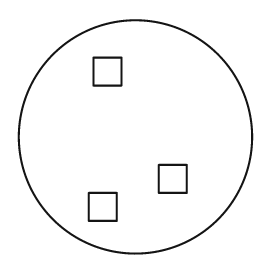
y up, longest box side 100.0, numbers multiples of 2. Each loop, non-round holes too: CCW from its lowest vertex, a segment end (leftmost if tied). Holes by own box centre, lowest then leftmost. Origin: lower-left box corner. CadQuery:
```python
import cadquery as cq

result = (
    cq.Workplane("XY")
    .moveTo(50.0, 50.0)
    .circle(50.0)
    .moveTo(30.0, 14.0)
    .lineTo(42.0, 14.0)
    .lineTo(42.0, 26.0)
    .lineTo(30.0, 26.0)
    .close()
    .moveTo(60.0, 26.0)
    .lineTo(72.0, 26.0)
    .lineTo(72.0, 38.0)
    .lineTo(60.0, 38.0)
    .close()
    .moveTo(32.0, 72.0)
    .lineTo(44.0, 72.0)
    .lineTo(44.0, 84.0)
    .lineTo(32.0, 84.0)
    .close()
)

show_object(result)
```